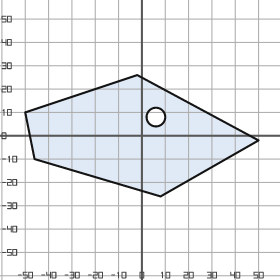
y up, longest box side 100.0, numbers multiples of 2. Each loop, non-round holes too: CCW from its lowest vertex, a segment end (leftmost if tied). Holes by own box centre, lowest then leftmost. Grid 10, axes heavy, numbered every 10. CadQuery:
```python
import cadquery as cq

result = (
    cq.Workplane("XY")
    .moveTo(8.0, -26.0)
    .lineTo(50.0, -2.0)
    .lineTo(-2.0, 26.0)
    .lineTo(-50.0, 10.0)
    .lineTo(-46.0, -10.0)
    .close()
    .moveTo(6.0, 8.0)
    .circle(4.0)
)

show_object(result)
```